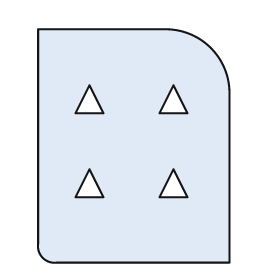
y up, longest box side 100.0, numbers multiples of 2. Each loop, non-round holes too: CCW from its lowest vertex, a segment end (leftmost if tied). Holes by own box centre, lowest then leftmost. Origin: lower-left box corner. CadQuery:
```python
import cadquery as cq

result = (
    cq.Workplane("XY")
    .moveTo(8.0, 0.0)
    .lineTo(82.0, 0.0)
    .lineTo(82.0, 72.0)
    .threePointArc((74.0, 92.0), (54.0, 100.0))
    .lineTo(0.0, 100.0)
    .lineTo(0.0, 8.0)
    .threePointArc((2.0, 2.0), (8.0, 0.0))
    .close()
    .moveTo(16.0, 28.0)
    .lineTo(28.0, 28.0)
    .lineTo(22.0, 40.0)
    .close()
    .moveTo(52.0, 28.0)
    .lineTo(64.0, 28.0)
    .lineTo(58.0, 40.0)
    .close()
    .moveTo(16.0, 64.0)
    .lineTo(28.0, 64.0)
    .lineTo(22.0, 76.0)
    .close()
    .moveTo(52.0, 64.0)
    .lineTo(64.0, 64.0)
    .lineTo(58.0, 76.0)
    .close()
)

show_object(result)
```